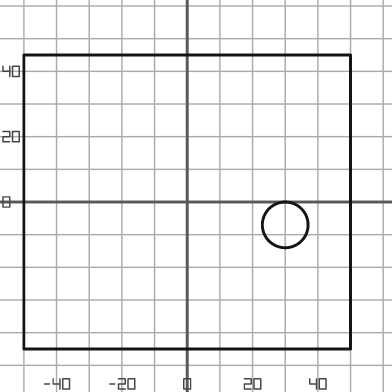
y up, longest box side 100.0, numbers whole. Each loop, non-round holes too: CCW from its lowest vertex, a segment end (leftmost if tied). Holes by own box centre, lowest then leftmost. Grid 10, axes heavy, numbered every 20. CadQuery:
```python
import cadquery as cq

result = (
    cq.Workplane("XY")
    .moveTo(-50.0, -45.0)
    .lineTo(50.0, -45.0)
    .lineTo(50.0, 45.0)
    .lineTo(-50.0, 45.0)
    .close()
    .moveTo(30.0, -7.0)
    .circle(7.0)
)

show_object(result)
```